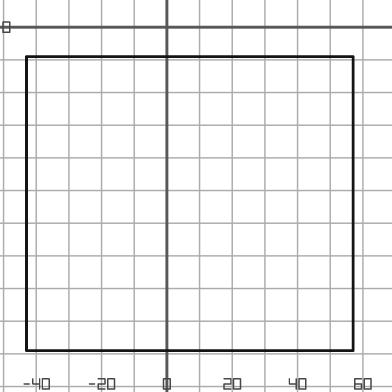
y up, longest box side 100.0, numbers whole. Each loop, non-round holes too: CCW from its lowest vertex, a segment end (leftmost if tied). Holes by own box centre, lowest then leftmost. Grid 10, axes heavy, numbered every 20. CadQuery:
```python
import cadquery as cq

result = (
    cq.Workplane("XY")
    .moveTo(-43.0, -99.0)
    .lineTo(57.0, -99.0)
    .lineTo(57.0, -9.0)
    .lineTo(-43.0, -9.0)
    .close()
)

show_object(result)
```